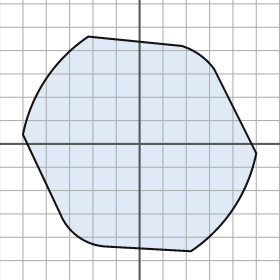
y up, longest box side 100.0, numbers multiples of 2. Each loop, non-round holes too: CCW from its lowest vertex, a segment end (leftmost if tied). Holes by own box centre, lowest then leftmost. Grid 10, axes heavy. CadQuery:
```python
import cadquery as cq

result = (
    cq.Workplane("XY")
    .moveTo(22.0, -46.0)
    .threePointArc((40.0, -28.0), (50.0, -4.0))
    .lineTo(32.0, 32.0)
    .threePointArc((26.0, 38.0), (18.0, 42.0))
    .lineTo(-22.0, 46.0)
    .threePointArc((-40.0, 28.0), (-50.0, 4.0))
    .lineTo(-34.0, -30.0)
    .threePointArc((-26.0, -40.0), (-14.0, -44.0))
    .close()
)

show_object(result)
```